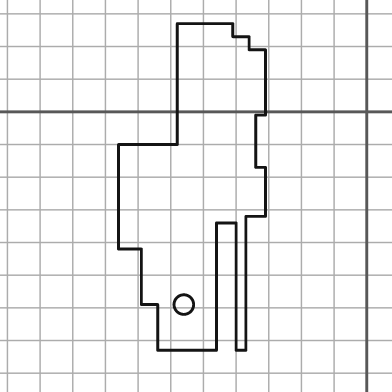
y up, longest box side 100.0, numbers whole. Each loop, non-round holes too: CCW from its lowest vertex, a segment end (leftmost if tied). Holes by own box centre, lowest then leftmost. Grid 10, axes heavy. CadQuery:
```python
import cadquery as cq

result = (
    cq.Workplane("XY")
    .moveTo(-64.0, -73.0)
    .lineTo(-46.0, -73.0)
    .lineTo(-46.0, -34.0)
    .lineTo(-40.0, -34.0)
    .lineTo(-40.0, -73.0)
    .lineTo(-37.0, -73.0)
    .lineTo(-37.0, -32.0)
    .lineTo(-31.0, -32.0)
    .lineTo(-31.0, -17.0)
    .lineTo(-34.0, -17.0)
    .lineTo(-34.0, -1.0)
    .lineTo(-31.0, -1.0)
    .lineTo(-31.0, 19.0)
    .lineTo(-36.0, 19.0)
    .lineTo(-36.0, 23.0)
    .lineTo(-41.0, 23.0)
    .lineTo(-41.0, 27.0)
    .lineTo(-58.0, 27.0)
    .lineTo(-58.0, -10.0)
    .lineTo(-76.0, -10.0)
    .lineTo(-76.0, -42.0)
    .lineTo(-69.0, -42.0)
    .lineTo(-69.0, -59.0)
    .lineTo(-64.0, -59.0)
    .close()
    .moveTo(-56.0, -59.0)
    .circle(3.0)
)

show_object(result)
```